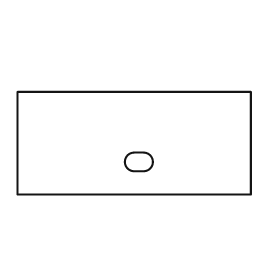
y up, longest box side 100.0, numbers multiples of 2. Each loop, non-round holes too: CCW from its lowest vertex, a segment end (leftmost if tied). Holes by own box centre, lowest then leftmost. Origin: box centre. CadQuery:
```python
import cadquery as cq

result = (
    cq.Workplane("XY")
    .moveTo(-50.0, -22.0)
    .lineTo(50.0, -22.0)
    .lineTo(50.0, 22.0)
    .lineTo(-50.0, 22.0)
    .close()
    .moveTo(0.0, -12.0)
    .lineTo(4.0, -12.0)
    .threePointArc((8.0, -8.0), (4.0, -4.0))
    .lineTo(0.0, -4.0)
    .threePointArc((-4.0, -8.0), (0.0, -12.0))
    .close()
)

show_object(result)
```